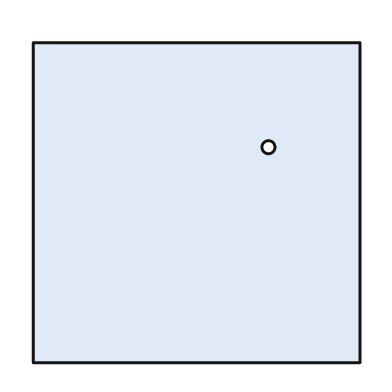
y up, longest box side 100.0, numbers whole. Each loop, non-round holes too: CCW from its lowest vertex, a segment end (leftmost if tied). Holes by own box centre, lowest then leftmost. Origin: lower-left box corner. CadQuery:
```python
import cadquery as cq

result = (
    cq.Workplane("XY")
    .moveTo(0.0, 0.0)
    .lineTo(100.0, 0.0)
    .lineTo(100.0, 98.0)
    .lineTo(0.0, 98.0)
    .close()
    .moveTo(72.0, 66.0)
    .circle(2.0)
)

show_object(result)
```